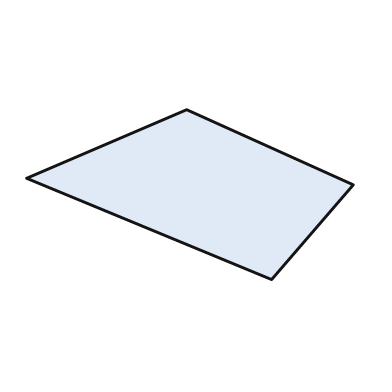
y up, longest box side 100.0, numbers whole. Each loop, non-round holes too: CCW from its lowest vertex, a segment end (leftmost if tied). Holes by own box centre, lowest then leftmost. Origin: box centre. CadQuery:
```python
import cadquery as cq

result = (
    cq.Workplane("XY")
    .moveTo(25.0, -26.0)
    .lineTo(50.0, 3.0)
    .lineTo(-1.0, 26.0)
    .lineTo(-50.0, 5.0)
    .close()
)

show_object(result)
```